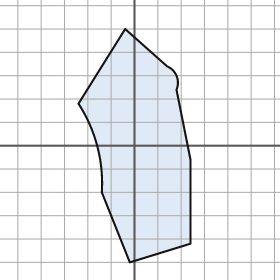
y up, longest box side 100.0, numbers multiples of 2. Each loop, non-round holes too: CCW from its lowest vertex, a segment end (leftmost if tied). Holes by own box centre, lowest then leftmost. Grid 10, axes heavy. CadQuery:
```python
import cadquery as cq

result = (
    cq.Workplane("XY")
    .moveTo(-2.0, -50.0)
    .lineTo(24.0, -42.0)
    .lineTo(24.0, -6.0)
    .lineTo(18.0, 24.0)
    .threePointArc((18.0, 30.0), (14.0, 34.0))
    .lineTo(-4.0, 50.0)
    .lineTo(-24.0, 18.0)
    .threePointArc((-16.0, 0.0), (-14.0, -20.0))
    .close()
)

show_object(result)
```